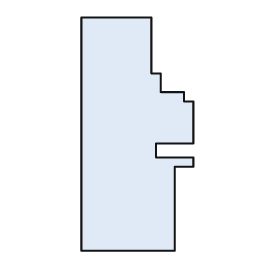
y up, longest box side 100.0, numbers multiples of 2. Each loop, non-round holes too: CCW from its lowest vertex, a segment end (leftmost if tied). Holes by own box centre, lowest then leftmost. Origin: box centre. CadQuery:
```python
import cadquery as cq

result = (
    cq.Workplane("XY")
    .moveTo(-24.0, -50.0)
    .lineTo(16.0, -50.0)
    .lineTo(16.0, -14.0)
    .lineTo(24.0, -14.0)
    .lineTo(24.0, -10.0)
    .lineTo(8.0, -10.0)
    .lineTo(8.0, -4.0)
    .lineTo(24.0, -4.0)
    .lineTo(24.0, 14.0)
    .lineTo(20.0, 14.0)
    .lineTo(20.0, 18.0)
    .lineTo(10.0, 18.0)
    .lineTo(10.0, 26.0)
    .lineTo(6.0, 26.0)
    .lineTo(6.0, 50.0)
    .lineTo(-24.0, 50.0)
    .close()
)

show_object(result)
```